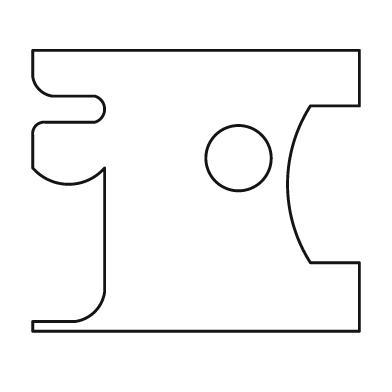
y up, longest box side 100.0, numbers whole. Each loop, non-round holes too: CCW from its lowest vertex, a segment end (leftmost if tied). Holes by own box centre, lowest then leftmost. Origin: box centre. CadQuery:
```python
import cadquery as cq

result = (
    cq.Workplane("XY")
    .moveTo(-50.0, -43.0)
    .lineTo(50.0, -43.0)
    .lineTo(50.0, -22.0)
    .lineTo(35.0, -22.0)
    .threePointArc((28.0, 2.0), (35.0, 26.0))
    .lineTo(50.0, 26.0)
    .lineTo(50.0, 43.0)
    .lineTo(-50.0, 43.0)
    .lineTo(-50.0, 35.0)
    .threePointArc((-48.0, 31.0), (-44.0, 29.0))
    .lineTo(-31.0, 29.0)
    .threePointArc((-28.0, 25.0), (-31.0, 21.0))
    .lineTo(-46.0, 21.0)
    .threePointArc((-49.0, 20.0), (-50.0, 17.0))
    .lineTo(-50.0, 7.0)
    .threePointArc((-39.0, 2.0), (-28.0, 7.0))
    .lineTo(-28.0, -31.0)
    .threePointArc((-31.0, -37.0), (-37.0, -40.0))
    .lineTo(-50.0, -40.0)
    .close()
    .moveTo(13.0, 10.0)
    .circle(10.0)
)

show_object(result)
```